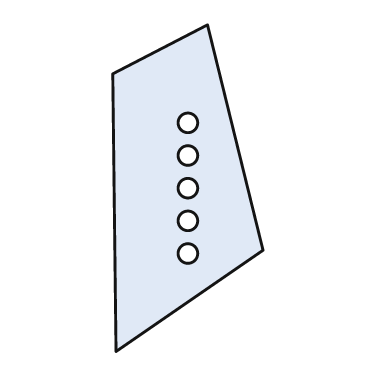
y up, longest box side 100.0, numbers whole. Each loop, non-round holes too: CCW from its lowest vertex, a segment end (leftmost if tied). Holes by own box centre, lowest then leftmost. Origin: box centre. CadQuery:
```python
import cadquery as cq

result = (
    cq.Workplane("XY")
    .moveTo(-22.0, -50.0)
    .lineTo(23.0, -19.0)
    .lineTo(6.0, 50.0)
    .lineTo(-23.0, 35.0)
    .close()
    .moveTo(0.0, -20.0)
    .circle(3.0)
    .moveTo(0.0, -10.0)
    .circle(3.0)
    .moveTo(0.0, 0.0)
    .circle(3.0)
    .moveTo(0.0, 10.0)
    .circle(3.0)
    .moveTo(0.0, 20.0)
    .circle(3.0)
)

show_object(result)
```